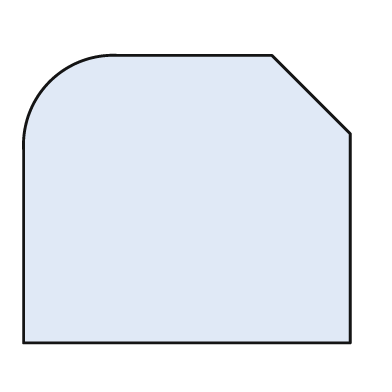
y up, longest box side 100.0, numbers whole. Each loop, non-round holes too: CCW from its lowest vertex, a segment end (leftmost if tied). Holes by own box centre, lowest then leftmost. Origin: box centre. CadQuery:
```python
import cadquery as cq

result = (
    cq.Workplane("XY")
    .moveTo(-50.0, -44.0)
    .lineTo(50.0, -44.0)
    .lineTo(50.0, 20.0)
    .lineTo(26.0, 44.0)
    .lineTo(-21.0, 44.0)
    .threePointArc((-42.0, 36.0), (-50.0, 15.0))
    .close()
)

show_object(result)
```